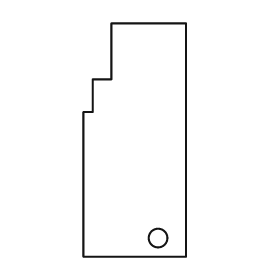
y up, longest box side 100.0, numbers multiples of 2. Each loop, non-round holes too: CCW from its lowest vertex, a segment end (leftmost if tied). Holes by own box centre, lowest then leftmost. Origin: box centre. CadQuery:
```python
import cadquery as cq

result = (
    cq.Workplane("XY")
    .moveTo(-22.0, -50.0)
    .lineTo(22.0, -50.0)
    .lineTo(22.0, 50.0)
    .lineTo(-10.0, 50.0)
    .lineTo(-10.0, 26.0)
    .lineTo(-18.0, 26.0)
    .lineTo(-18.0, 12.0)
    .lineTo(-22.0, 12.0)
    .close()
    .moveTo(10.0, -42.0)
    .circle(4.0)
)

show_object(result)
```